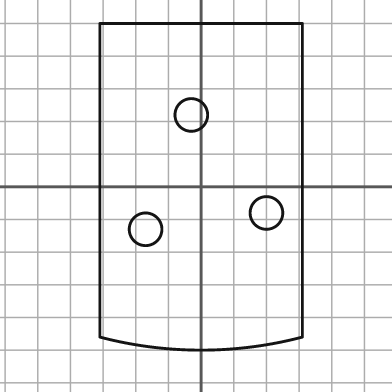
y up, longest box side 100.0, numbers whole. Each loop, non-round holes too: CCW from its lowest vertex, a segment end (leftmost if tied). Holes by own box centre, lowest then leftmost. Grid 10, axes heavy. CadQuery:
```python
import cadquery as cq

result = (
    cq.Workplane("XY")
    .moveTo(-31.0, -46.0)
    .threePointArc((0.0, -50.0), (31.0, -46.0))
    .lineTo(31.0, 50.0)
    .lineTo(-31.0, 50.0)
    .close()
    .moveTo(-17.0, -13.0)
    .circle(5.0)
    .moveTo(20.0, -8.0)
    .circle(5.0)
    .moveTo(-3.0, 22.0)
    .circle(5.0)
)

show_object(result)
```